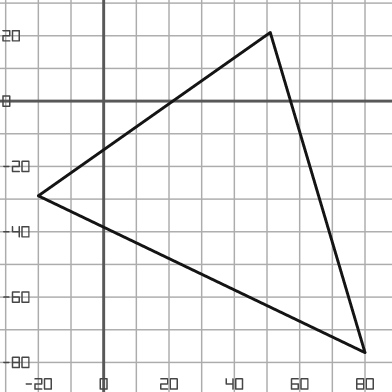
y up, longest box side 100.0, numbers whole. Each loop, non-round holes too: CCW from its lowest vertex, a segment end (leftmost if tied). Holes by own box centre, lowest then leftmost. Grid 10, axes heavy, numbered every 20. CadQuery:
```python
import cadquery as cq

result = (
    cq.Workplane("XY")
    .moveTo(80.0, -77.0)
    .lineTo(51.0, 21.0)
    .lineTo(-20.0, -29.0)
    .close()
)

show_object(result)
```